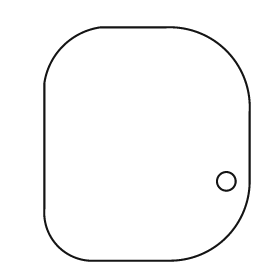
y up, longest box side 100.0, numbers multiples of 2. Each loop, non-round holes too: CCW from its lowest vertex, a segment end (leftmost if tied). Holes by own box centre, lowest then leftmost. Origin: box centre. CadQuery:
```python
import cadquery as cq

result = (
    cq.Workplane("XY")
    .moveTo(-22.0, -50.0)
    .lineTo(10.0, -50.0)
    .threePointArc((34.0, -40.0), (44.0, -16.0))
    .lineTo(44.0, 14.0)
    .threePointArc((34.0, 40.0), (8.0, 50.0))
    .lineTo(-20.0, 50.0)
    .threePointArc((-36.0, 42.0), (-44.0, 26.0))
    .lineTo(-44.0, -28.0)
    .threePointArc((-38.0, -44.0), (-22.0, -50.0))
    .close()
    .moveTo(34.0, -16.0)
    .circle(4.0)
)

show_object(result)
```